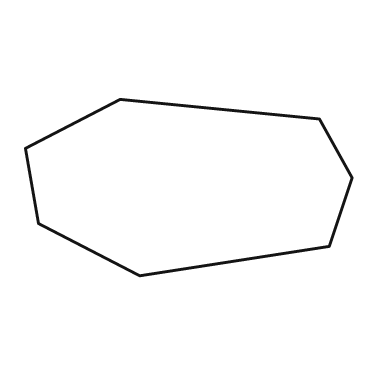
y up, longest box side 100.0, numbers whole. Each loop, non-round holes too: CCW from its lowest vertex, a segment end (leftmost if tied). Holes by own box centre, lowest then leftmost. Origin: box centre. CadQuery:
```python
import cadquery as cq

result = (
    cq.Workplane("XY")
    .moveTo(-15.0, -27.0)
    .lineTo(43.0, -18.0)
    .lineTo(50.0, 3.0)
    .lineTo(40.0, 21.0)
    .lineTo(-21.0, 27.0)
    .lineTo(-50.0, 12.0)
    .lineTo(-46.0, -11.0)
    .close()
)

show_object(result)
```